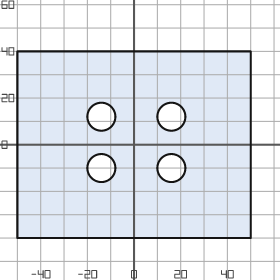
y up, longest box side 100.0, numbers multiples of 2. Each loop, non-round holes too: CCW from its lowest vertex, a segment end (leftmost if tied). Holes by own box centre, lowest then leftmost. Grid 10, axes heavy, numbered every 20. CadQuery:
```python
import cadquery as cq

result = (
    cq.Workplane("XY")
    .moveTo(-50.0, -40.0)
    .lineTo(50.0, -40.0)
    .lineTo(50.0, 40.0)
    .lineTo(-50.0, 40.0)
    .close()
    .moveTo(-14.0, -10.0)
    .circle(6.0)
    .moveTo(16.0, -10.0)
    .circle(6.0)
    .moveTo(-14.0, 12.0)
    .circle(6.0)
    .moveTo(16.0, 12.0)
    .circle(6.0)
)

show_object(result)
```